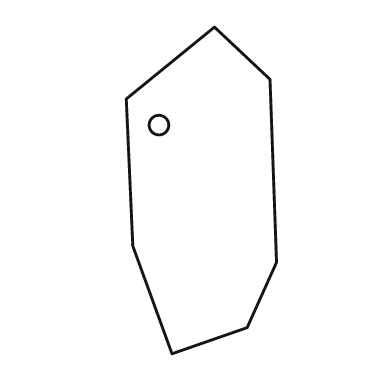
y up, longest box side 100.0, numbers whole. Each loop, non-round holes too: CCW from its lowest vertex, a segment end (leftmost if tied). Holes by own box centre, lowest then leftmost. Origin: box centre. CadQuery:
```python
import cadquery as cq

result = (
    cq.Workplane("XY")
    .moveTo(-9.0, -50.0)
    .lineTo(14.0, -42.0)
    .lineTo(23.0, -22.0)
    .lineTo(21.0, 34.0)
    .lineTo(4.0, 50.0)
    .lineTo(-23.0, 28.0)
    .lineTo(-21.0, -17.0)
    .close()
    .moveTo(-13.0, 20.0)
    .circle(3.0)
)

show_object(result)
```